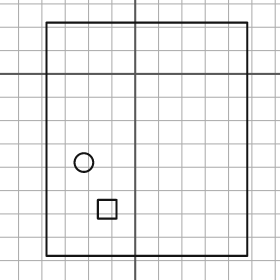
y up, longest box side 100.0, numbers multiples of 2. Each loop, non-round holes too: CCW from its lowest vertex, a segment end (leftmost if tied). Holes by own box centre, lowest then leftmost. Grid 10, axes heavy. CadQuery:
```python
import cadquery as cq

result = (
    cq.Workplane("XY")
    .moveTo(-38.0, -78.0)
    .lineTo(48.0, -78.0)
    .lineTo(48.0, 22.0)
    .lineTo(-38.0, 22.0)
    .close()
    .moveTo(-16.0, -62.0)
    .lineTo(-8.0, -62.0)
    .lineTo(-8.0, -54.0)
    .lineTo(-16.0, -54.0)
    .close()
    .moveTo(-22.0, -38.0)
    .circle(4.0)
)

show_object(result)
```